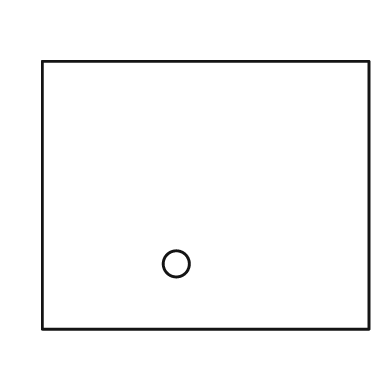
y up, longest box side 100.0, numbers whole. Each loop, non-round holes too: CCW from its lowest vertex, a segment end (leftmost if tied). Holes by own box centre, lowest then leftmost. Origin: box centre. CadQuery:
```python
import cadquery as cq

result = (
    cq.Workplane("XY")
    .moveTo(-50.0, -41.0)
    .lineTo(50.0, -41.0)
    .lineTo(50.0, 41.0)
    .lineTo(-50.0, 41.0)
    .close()
    .moveTo(-9.0, -21.0)
    .circle(4.0)
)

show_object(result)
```